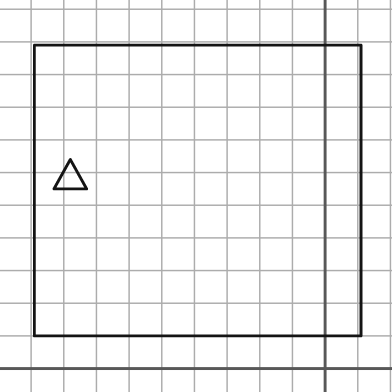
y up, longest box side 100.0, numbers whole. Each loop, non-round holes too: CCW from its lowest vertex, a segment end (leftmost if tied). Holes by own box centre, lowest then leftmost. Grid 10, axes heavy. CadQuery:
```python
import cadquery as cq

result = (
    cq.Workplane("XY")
    .moveTo(-89.0, 10.0)
    .lineTo(11.0, 10.0)
    .lineTo(11.0, 99.0)
    .lineTo(-89.0, 99.0)
    .close()
    .moveTo(-83.0, 55.0)
    .lineTo(-73.0, 55.0)
    .lineTo(-78.0, 64.0)
    .close()
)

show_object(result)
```